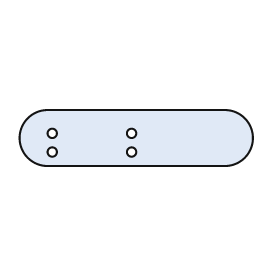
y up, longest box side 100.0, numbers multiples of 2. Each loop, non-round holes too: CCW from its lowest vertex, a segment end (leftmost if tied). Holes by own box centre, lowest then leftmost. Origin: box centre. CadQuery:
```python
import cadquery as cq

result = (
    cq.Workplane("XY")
    .moveTo(-38.0, -12.0)
    .lineTo(38.0, -12.0)
    .threePointArc((50.0, 0.0), (38.0, 12.0))
    .lineTo(-38.0, 12.0)
    .threePointArc((-50.0, 0.0), (-38.0, -12.0))
    .close()
    .moveTo(-36.0, -6.0)
    .circle(2.0)
    .moveTo(-2.0, -6.0)
    .circle(2.0)
    .moveTo(-36.0, 2.0)
    .circle(2.0)
    .moveTo(-2.0, 2.0)
    .circle(2.0)
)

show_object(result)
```